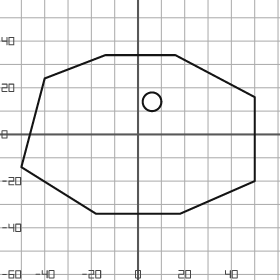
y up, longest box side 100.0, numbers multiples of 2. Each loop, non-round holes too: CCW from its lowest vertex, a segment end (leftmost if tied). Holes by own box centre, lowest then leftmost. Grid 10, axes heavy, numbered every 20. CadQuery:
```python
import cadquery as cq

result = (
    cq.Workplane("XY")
    .moveTo(-18.0, -34.0)
    .lineTo(18.0, -34.0)
    .lineTo(50.0, -20.0)
    .lineTo(50.0, 16.0)
    .lineTo(16.0, 34.0)
    .lineTo(-14.0, 34.0)
    .lineTo(-40.0, 24.0)
    .lineTo(-50.0, -14.0)
    .close()
    .moveTo(6.0, 14.0)
    .circle(4.0)
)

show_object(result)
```